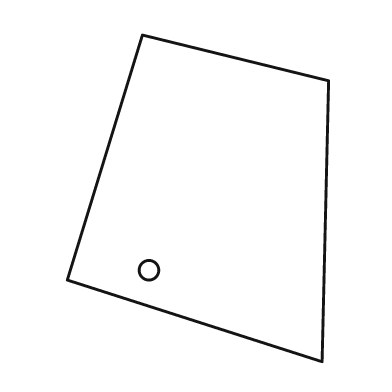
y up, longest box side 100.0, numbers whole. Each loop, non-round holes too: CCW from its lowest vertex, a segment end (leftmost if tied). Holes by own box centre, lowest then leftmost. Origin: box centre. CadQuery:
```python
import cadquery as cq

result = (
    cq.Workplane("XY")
    .moveTo(38.0, -50.0)
    .lineTo(40.0, 36.0)
    .lineTo(-17.0, 50.0)
    .lineTo(-40.0, -25.0)
    .close()
    .moveTo(-15.0, -22.0)
    .circle(3.0)
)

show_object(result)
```